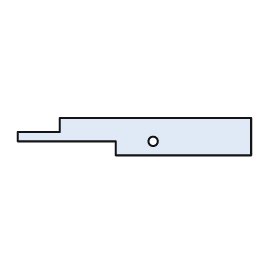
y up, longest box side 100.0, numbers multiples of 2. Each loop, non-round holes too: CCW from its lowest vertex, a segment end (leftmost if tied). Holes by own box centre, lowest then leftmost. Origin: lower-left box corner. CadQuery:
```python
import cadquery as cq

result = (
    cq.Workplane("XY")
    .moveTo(42.0, 0.0)
    .lineTo(100.0, 0.0)
    .lineTo(100.0, 16.0)
    .lineTo(18.0, 16.0)
    .lineTo(18.0, 10.0)
    .lineTo(0.0, 10.0)
    .lineTo(0.0, 6.0)
    .lineTo(42.0, 6.0)
    .close()
    .moveTo(58.0, 6.0)
    .circle(2.0)
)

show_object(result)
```